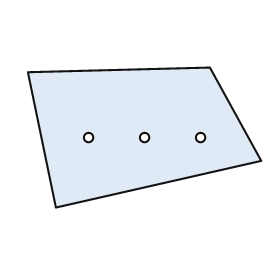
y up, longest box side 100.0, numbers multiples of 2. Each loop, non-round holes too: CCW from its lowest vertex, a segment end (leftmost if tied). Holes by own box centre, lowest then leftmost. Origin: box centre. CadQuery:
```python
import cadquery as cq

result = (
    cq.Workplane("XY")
    .moveTo(-38.0, -30.0)
    .lineTo(50.0, -10.0)
    .lineTo(28.0, 30.0)
    .lineTo(-50.0, 28.0)
    .close()
    .moveTo(-24.0, 0.0)
    .circle(2.0)
    .moveTo(0.0, 0.0)
    .circle(2.0)
    .moveTo(24.0, 0.0)
    .circle(2.0)
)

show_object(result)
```